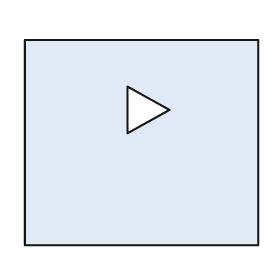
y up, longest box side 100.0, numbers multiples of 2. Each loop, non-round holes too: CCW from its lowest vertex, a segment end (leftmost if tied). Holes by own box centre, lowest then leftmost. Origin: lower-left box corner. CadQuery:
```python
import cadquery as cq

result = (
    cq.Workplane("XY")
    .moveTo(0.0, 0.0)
    .lineTo(100.0, 0.0)
    .lineTo(100.0, 88.0)
    .lineTo(0.0, 88.0)
    .close()
    .moveTo(44.0, 48.0)
    .lineTo(62.0, 58.0)
    .lineTo(44.0, 68.0)
    .close()
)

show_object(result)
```